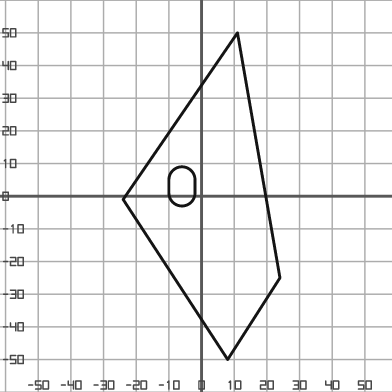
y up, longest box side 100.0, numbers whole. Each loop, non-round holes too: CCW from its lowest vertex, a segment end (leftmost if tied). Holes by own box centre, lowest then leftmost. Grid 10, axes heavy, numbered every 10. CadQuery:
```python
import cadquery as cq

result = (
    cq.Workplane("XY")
    .moveTo(8.0, -50.0)
    .lineTo(24.0, -25.0)
    .lineTo(11.0, 50.0)
    .lineTo(-24.0, -1.0)
    .close()
    .moveTo(-10.0, 1.0)
    .threePointArc((-6.0, -3.0), (-2.0, 1.0))
    .lineTo(-2.0, 5.0)
    .threePointArc((-6.0, 9.0), (-10.0, 5.0))
    .close()
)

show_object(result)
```